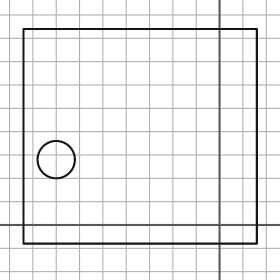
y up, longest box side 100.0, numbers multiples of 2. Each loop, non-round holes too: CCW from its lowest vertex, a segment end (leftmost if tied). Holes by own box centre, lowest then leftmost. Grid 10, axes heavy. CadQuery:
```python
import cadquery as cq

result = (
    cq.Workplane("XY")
    .moveTo(-84.0, -8.0)
    .lineTo(16.0, -8.0)
    .lineTo(16.0, 84.0)
    .lineTo(-84.0, 84.0)
    .close()
    .moveTo(-70.0, 28.0)
    .circle(8.0)
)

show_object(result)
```